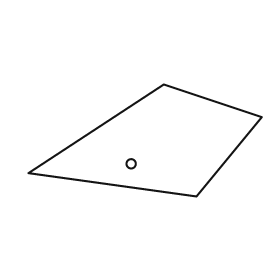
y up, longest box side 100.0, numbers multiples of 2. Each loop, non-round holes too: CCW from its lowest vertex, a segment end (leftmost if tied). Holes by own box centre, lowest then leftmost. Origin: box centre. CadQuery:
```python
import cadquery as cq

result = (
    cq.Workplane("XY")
    .moveTo(22.0, -24.0)
    .lineTo(50.0, 10.0)
    .lineTo(8.0, 24.0)
    .lineTo(-50.0, -14.0)
    .close()
    .moveTo(-6.0, -10.0)
    .circle(2.0)
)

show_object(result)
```